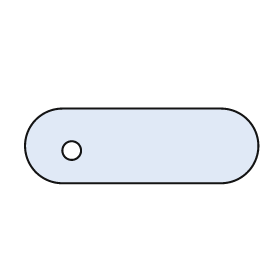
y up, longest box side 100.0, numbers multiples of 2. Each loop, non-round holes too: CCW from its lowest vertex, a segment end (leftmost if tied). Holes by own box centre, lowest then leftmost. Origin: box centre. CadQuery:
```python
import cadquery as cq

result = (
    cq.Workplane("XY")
    .moveTo(-34.0, -16.0)
    .lineTo(34.0, -16.0)
    .threePointArc((50.0, 0.0), (34.0, 16.0))
    .lineTo(-34.0, 16.0)
    .threePointArc((-50.0, 0.0), (-34.0, -16.0))
    .close()
    .moveTo(-30.0, -2.0)
    .circle(4.0)
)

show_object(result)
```